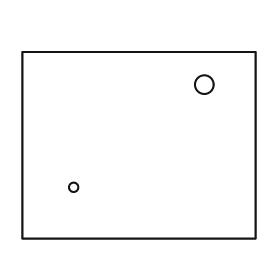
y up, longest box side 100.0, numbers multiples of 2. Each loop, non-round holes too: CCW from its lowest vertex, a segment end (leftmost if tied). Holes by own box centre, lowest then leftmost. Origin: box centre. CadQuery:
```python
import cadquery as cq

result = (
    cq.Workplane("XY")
    .moveTo(-50.0, -40.0)
    .lineTo(50.0, -40.0)
    .lineTo(50.0, 40.0)
    .lineTo(-50.0, 40.0)
    .close()
    .moveTo(-28.0, -18.0)
    .circle(2.0)
    .moveTo(28.0, 26.0)
    .circle(4.0)
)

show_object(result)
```